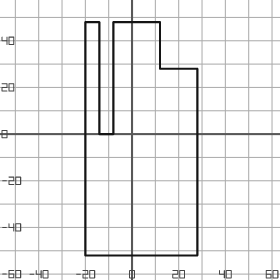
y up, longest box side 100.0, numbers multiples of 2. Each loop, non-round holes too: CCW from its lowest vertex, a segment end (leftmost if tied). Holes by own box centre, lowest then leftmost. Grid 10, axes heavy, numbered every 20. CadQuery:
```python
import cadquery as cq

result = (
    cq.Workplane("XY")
    .moveTo(-20.0, -52.0)
    .lineTo(28.0, -52.0)
    .lineTo(28.0, 28.0)
    .lineTo(12.0, 28.0)
    .lineTo(12.0, 48.0)
    .lineTo(-8.0, 48.0)
    .lineTo(-8.0, 0.0)
    .lineTo(-14.0, 0.0)
    .lineTo(-14.0, 48.0)
    .lineTo(-20.0, 48.0)
    .close()
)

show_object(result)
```